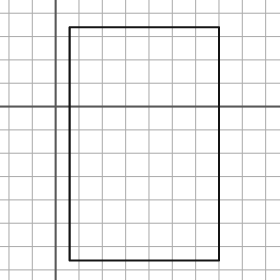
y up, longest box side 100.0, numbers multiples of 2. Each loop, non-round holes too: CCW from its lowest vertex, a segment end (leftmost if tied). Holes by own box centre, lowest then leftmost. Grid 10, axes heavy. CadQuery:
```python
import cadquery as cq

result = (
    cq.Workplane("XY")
    .moveTo(6.0, -66.0)
    .lineTo(70.0, -66.0)
    .lineTo(70.0, 34.0)
    .lineTo(6.0, 34.0)
    .close()
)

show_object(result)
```